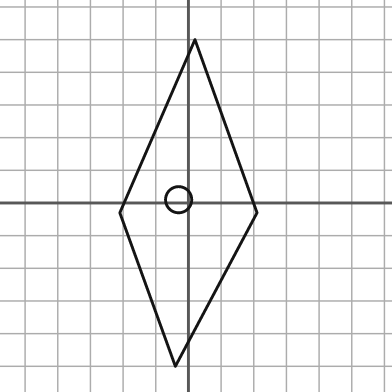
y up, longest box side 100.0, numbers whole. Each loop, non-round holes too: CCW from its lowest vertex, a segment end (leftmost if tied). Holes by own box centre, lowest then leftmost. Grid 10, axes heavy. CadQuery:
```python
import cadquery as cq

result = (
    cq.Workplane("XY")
    .moveTo(-4.0, -50.0)
    .lineTo(21.0, -3.0)
    .lineTo(2.0, 50.0)
    .lineTo(-21.0, -3.0)
    .close()
    .moveTo(-3.0, 1.0)
    .circle(4.0)
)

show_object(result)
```